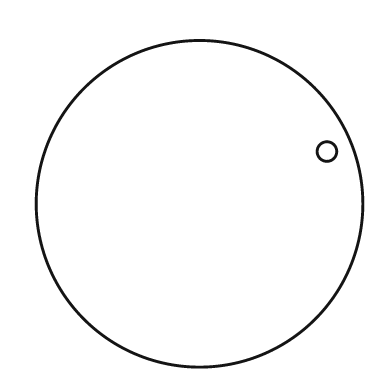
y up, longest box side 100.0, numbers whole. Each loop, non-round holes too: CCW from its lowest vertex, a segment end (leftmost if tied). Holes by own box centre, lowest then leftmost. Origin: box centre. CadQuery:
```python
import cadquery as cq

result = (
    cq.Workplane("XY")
    .moveTo(0.0, 0.0)
    .circle(50.0)
    .moveTo(39.0, 16.0)
    .circle(3.0)
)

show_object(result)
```